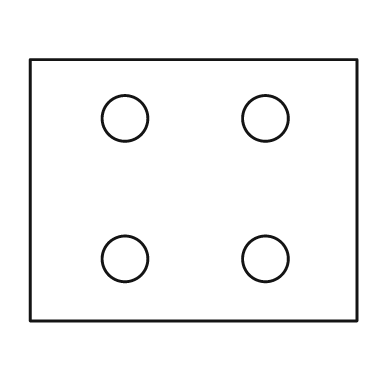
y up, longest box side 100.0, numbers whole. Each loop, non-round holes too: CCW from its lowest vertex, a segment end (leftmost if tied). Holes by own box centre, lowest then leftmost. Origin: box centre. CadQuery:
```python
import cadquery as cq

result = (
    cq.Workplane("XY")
    .moveTo(-50.0, -40.0)
    .lineTo(50.0, -40.0)
    .lineTo(50.0, 40.0)
    .lineTo(-50.0, 40.0)
    .close()
    .moveTo(-21.0, -21.0)
    .circle(7.0)
    .moveTo(22.0, -21.0)
    .circle(7.0)
    .moveTo(-21.0, 22.0)
    .circle(7.0)
    .moveTo(22.0, 22.0)
    .circle(7.0)
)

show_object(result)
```